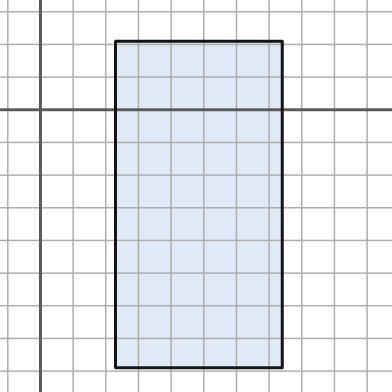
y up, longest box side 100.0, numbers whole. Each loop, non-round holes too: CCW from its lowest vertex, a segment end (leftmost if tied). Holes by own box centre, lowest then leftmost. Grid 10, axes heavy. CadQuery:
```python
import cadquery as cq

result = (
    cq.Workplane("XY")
    .moveTo(23.0, -79.0)
    .lineTo(74.0, -79.0)
    .lineTo(74.0, 21.0)
    .lineTo(23.0, 21.0)
    .close()
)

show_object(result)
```